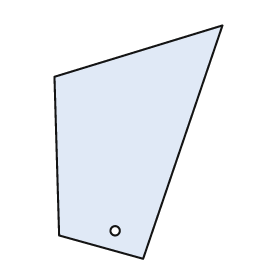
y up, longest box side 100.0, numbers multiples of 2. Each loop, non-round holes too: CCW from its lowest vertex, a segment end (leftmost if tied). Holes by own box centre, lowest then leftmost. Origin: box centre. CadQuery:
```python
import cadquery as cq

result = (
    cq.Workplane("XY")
    .moveTo(2.0, -50.0)
    .lineTo(36.0, 50.0)
    .lineTo(-36.0, 28.0)
    .lineTo(-34.0, -40.0)
    .close()
    .moveTo(-10.0, -38.0)
    .circle(2.0)
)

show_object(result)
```